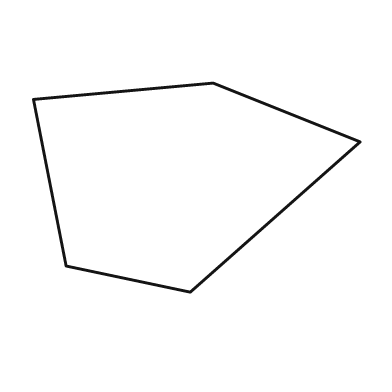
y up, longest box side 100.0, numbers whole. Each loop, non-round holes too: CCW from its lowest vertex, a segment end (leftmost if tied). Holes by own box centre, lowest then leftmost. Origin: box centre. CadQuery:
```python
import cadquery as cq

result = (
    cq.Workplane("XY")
    .moveTo(-2.0, -32.0)
    .lineTo(50.0, 14.0)
    .lineTo(5.0, 32.0)
    .lineTo(-50.0, 27.0)
    .lineTo(-40.0, -24.0)
    .close()
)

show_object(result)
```